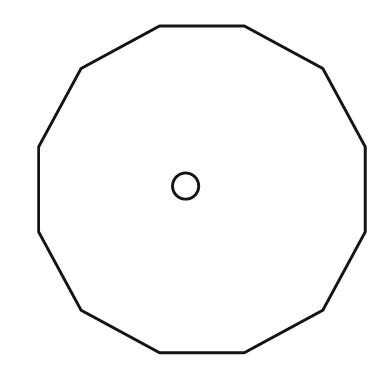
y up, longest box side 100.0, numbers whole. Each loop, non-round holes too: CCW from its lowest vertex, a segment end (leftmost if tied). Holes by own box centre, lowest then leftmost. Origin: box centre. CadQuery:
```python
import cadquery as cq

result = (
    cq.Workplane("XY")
    .moveTo(-13.0, -50.0)
    .lineTo(13.0, -50.0)
    .lineTo(37.0, -37.0)
    .lineTo(50.0, -13.0)
    .lineTo(50.0, 13.0)
    .lineTo(37.0, 37.0)
    .lineTo(13.0, 50.0)
    .lineTo(-13.0, 50.0)
    .lineTo(-37.0, 37.0)
    .lineTo(-50.0, 13.0)
    .lineTo(-50.0, -13.0)
    .lineTo(-37.0, -37.0)
    .close()
    .moveTo(-5.0, 1.0)
    .circle(4.0)
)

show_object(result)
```